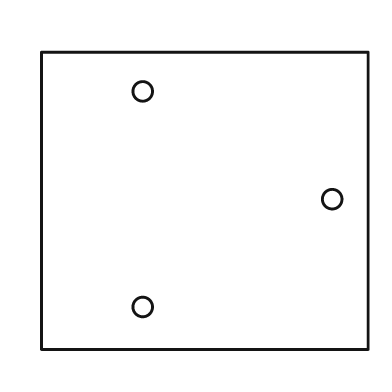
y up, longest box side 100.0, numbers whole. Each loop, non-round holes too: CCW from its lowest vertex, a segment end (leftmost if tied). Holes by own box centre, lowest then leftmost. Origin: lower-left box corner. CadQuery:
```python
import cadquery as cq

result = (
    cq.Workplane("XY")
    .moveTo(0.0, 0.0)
    .lineTo(100.0, 0.0)
    .lineTo(100.0, 91.0)
    .lineTo(0.0, 91.0)
    .close()
    .moveTo(31.0, 13.0)
    .circle(3.0)
    .moveTo(89.0, 46.0)
    .circle(3.0)
    .moveTo(31.0, 79.0)
    .circle(3.0)
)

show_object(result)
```